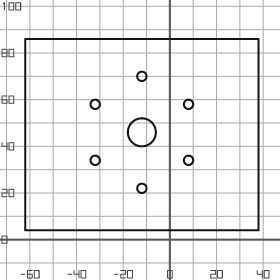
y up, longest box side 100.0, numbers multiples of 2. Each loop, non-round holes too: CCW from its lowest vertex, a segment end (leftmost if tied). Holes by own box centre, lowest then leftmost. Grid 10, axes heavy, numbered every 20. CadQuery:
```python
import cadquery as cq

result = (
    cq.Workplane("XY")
    .moveTo(-62.0, 4.0)
    .lineTo(38.0, 4.0)
    .lineTo(38.0, 86.0)
    .lineTo(-62.0, 86.0)
    .close()
    .moveTo(-12.0, 22.0)
    .circle(2.0)
    .moveTo(-32.0, 34.0)
    .circle(2.0)
    .moveTo(8.0, 34.0)
    .circle(2.0)
    .moveTo(-12.0, 46.0)
    .circle(6.0)
    .moveTo(-32.0, 58.0)
    .circle(2.0)
    .moveTo(8.0, 58.0)
    .circle(2.0)
    .moveTo(-12.0, 70.0)
    .circle(2.0)
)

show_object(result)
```